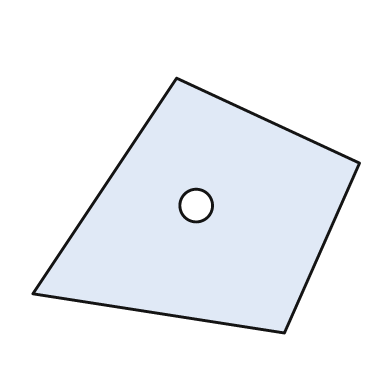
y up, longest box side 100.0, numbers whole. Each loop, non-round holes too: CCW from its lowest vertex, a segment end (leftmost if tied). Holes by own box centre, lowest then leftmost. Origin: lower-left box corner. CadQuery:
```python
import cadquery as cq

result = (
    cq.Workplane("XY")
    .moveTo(77.0, 0.0)
    .lineTo(100.0, 52.0)
    .lineTo(44.0, 78.0)
    .lineTo(0.0, 12.0)
    .close()
    .moveTo(50.0, 39.0)
    .circle(5.0)
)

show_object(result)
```